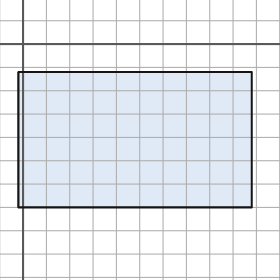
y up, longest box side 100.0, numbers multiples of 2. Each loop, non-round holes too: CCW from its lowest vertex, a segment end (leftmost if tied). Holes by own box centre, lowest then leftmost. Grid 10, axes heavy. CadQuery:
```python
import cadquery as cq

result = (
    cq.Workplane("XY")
    .moveTo(-2.0, -70.0)
    .lineTo(98.0, -70.0)
    .lineTo(98.0, -12.0)
    .lineTo(-2.0, -12.0)
    .close()
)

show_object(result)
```